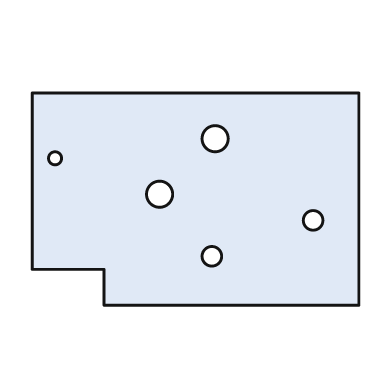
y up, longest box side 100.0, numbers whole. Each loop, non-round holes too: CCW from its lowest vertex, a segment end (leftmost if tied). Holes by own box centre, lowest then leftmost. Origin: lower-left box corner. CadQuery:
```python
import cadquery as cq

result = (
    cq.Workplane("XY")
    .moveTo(22.0, 0.0)
    .lineTo(100.0, 0.0)
    .lineTo(100.0, 65.0)
    .lineTo(0.0, 65.0)
    .lineTo(0.0, 11.0)
    .lineTo(22.0, 11.0)
    .close()
    .moveTo(55.0, 15.0)
    .circle(3.0)
    .moveTo(86.0, 26.0)
    .circle(3.0)
    .moveTo(39.0, 34.0)
    .circle(4.0)
    .moveTo(7.0, 45.0)
    .circle(2.0)
    .moveTo(56.0, 51.0)
    .circle(4.0)
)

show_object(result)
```